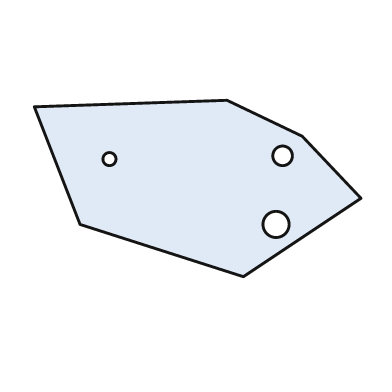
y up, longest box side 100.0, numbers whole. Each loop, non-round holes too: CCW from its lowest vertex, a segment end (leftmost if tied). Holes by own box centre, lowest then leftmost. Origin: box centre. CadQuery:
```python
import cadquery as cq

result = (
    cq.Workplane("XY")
    .moveTo(14.0, -27.0)
    .lineTo(50.0, -3.0)
    .lineTo(32.0, 16.0)
    .lineTo(9.0, 27.0)
    .lineTo(-50.0, 25.0)
    .lineTo(-36.0, -11.0)
    .close()
    .moveTo(24.0, -11.0)
    .circle(4.0)
    .moveTo(-27.0, 9.0)
    .circle(2.0)
    .moveTo(26.0, 10.0)
    .circle(3.0)
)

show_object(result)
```